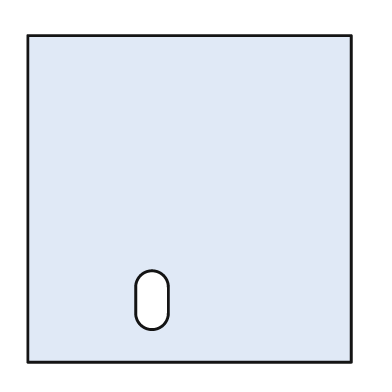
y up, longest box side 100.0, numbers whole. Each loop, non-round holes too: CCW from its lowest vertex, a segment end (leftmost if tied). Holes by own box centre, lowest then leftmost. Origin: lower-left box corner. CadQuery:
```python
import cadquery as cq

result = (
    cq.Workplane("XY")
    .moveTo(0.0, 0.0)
    .lineTo(99.0, 0.0)
    .lineTo(99.0, 100.0)
    .lineTo(0.0, 100.0)
    .close()
    .moveTo(33.0, 15.0)
    .threePointArc((38.0, 10.0), (43.0, 15.0))
    .lineTo(43.0, 23.0)
    .threePointArc((38.0, 28.0), (33.0, 23.0))
    .close()
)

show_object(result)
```